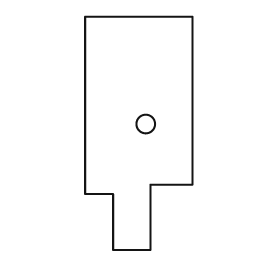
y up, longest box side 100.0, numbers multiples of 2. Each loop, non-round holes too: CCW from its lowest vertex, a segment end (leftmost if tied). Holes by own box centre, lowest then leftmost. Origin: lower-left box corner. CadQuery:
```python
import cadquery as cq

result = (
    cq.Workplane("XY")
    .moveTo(12.0, 0.0)
    .lineTo(28.0, 0.0)
    .lineTo(28.0, 28.0)
    .lineTo(46.0, 28.0)
    .lineTo(46.0, 100.0)
    .lineTo(0.0, 100.0)
    .lineTo(0.0, 24.0)
    .lineTo(12.0, 24.0)
    .close()
    .moveTo(26.0, 54.0)
    .circle(4.0)
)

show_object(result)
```